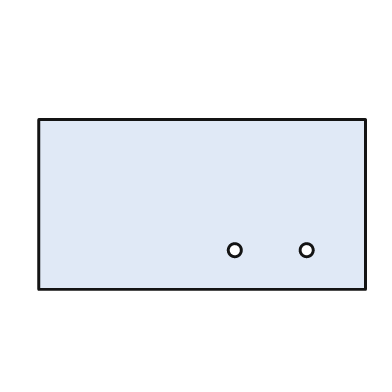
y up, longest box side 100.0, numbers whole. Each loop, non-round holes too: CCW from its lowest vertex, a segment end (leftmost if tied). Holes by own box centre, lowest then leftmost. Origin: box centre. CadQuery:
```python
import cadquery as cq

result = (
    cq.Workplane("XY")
    .moveTo(-50.0, -26.0)
    .lineTo(50.0, -26.0)
    .lineTo(50.0, 26.0)
    .lineTo(-50.0, 26.0)
    .close()
    .moveTo(10.0, -14.0)
    .circle(2.0)
    .moveTo(32.0, -14.0)
    .circle(2.0)
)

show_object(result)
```